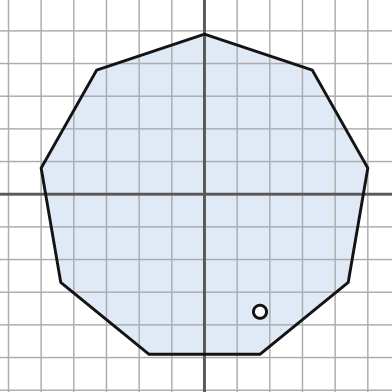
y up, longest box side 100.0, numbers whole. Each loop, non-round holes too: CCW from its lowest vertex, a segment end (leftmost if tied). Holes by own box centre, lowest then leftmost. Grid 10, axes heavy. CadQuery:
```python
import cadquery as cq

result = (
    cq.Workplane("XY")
    .moveTo(-17.0, -49.0)
    .lineTo(17.0, -49.0)
    .lineTo(44.0, -27.0)
    .lineTo(50.0, 8.0)
    .lineTo(33.0, 38.0)
    .lineTo(0.0, 49.0)
    .lineTo(-33.0, 38.0)
    .lineTo(-50.0, 8.0)
    .lineTo(-44.0, -27.0)
    .close()
    .moveTo(17.0, -36.0)
    .circle(2.0)
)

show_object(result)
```